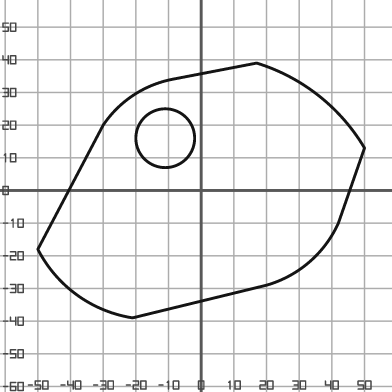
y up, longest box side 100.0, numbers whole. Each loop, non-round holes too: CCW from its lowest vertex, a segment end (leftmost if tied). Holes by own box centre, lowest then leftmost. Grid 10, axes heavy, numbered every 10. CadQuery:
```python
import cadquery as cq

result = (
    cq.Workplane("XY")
    .moveTo(-21.0, -39.0)
    .lineTo(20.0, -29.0)
    .threePointArc((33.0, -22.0), (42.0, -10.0))
    .lineTo(50.0, 13.0)
    .threePointArc((36.0, 29.0), (17.0, 39.0))
    .lineTo(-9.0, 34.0)
    .threePointArc((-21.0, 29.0), (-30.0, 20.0))
    .lineTo(-50.0, -18.0)
    .threePointArc((-38.0, -32.0), (-21.0, -39.0))
    .close()
    .moveTo(-11.0, 16.0)
    .circle(9.0)
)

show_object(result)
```